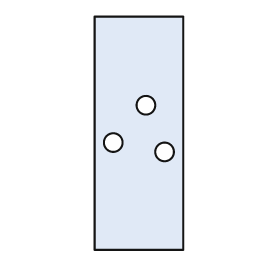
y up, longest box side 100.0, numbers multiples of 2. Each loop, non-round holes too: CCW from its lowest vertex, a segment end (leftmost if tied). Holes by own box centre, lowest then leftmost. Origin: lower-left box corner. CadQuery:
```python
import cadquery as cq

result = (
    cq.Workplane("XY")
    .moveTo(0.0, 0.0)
    .lineTo(38.0, 0.0)
    .lineTo(38.0, 100.0)
    .lineTo(0.0, 100.0)
    .close()
    .moveTo(30.0, 42.0)
    .circle(4.0)
    .moveTo(8.0, 46.0)
    .circle(4.0)
    .moveTo(22.0, 62.0)
    .circle(4.0)
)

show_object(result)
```